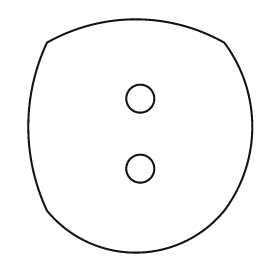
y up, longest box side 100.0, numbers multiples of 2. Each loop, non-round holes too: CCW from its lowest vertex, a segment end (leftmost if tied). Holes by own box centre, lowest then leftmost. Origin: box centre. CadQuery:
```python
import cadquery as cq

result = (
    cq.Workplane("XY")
    .moveTo(-40.0, -32.0)
    .threePointArc((-2.0, -50.0), (36.0, -32.0))
    .threePointArc((48.0, 4.0), (36.0, 40.0))
    .threePointArc((-2.0, 50.0), (-40.0, 40.0))
    .threePointArc((-48.0, 4.0), (-40.0, -32.0))
    .close()
    .moveTo(0.0, -14.0)
    .circle(6.0)
    .moveTo(0.0, 16.0)
    .circle(6.0)
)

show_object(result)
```